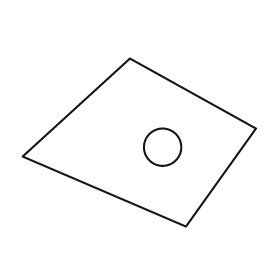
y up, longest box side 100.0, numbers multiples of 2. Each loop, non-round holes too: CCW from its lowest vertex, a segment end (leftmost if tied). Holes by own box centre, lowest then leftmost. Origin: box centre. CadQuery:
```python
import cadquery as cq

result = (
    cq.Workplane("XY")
    .moveTo(20.0, -36.0)
    .lineTo(50.0, 6.0)
    .lineTo(-4.0, 36.0)
    .lineTo(-50.0, -6.0)
    .close()
    .moveTo(10.0, -2.0)
    .circle(8.0)
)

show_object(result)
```